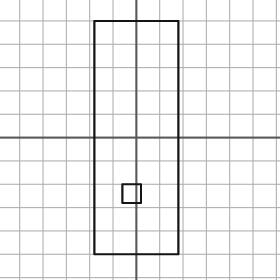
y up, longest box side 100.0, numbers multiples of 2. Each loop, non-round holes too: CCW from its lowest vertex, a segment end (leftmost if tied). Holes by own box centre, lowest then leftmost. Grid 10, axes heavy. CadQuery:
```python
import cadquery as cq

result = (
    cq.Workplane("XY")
    .moveTo(-18.0, -50.0)
    .lineTo(18.0, -50.0)
    .lineTo(18.0, 50.0)
    .lineTo(-18.0, 50.0)
    .close()
    .moveTo(-6.0, -28.0)
    .lineTo(2.0, -28.0)
    .lineTo(2.0, -20.0)
    .lineTo(-6.0, -20.0)
    .close()
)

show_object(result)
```